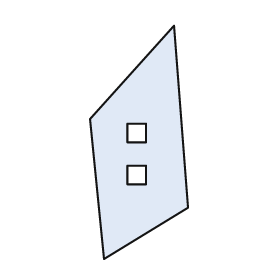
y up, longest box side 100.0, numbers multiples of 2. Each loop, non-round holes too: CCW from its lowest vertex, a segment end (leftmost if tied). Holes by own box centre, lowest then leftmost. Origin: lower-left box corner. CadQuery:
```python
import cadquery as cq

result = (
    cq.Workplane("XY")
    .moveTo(6.0, 0.0)
    .lineTo(42.0, 22.0)
    .lineTo(36.0, 100.0)
    .lineTo(0.0, 60.0)
    .close()
    .moveTo(16.0, 32.0)
    .lineTo(24.0, 32.0)
    .lineTo(24.0, 40.0)
    .lineTo(16.0, 40.0)
    .close()
    .moveTo(16.0, 50.0)
    .lineTo(24.0, 50.0)
    .lineTo(24.0, 58.0)
    .lineTo(16.0, 58.0)
    .close()
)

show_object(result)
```